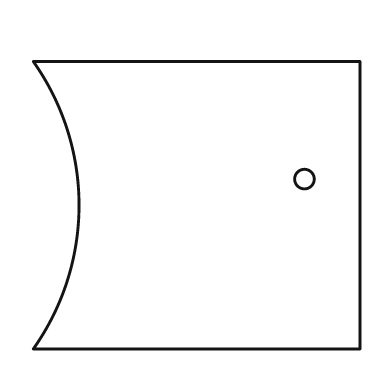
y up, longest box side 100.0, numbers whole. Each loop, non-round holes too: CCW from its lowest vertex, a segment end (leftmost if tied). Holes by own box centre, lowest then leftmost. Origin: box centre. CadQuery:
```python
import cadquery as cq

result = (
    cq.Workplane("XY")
    .moveTo(-50.0, -44.0)
    .lineTo(50.0, -44.0)
    .lineTo(50.0, 44.0)
    .lineTo(-50.0, 44.0)
    .threePointArc((-36.0, 0.0), (-50.0, -44.0))
    .close()
    .moveTo(33.0, 8.0)
    .circle(3.0)
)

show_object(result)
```